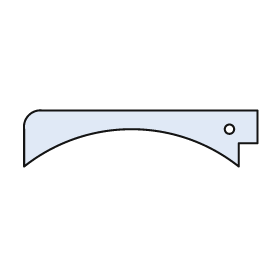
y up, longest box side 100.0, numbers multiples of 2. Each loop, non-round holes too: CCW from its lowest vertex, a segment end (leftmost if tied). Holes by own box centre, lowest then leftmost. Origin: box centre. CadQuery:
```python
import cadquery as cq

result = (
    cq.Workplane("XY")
    .moveTo(-50.0, -12.0)
    .threePointArc((-4.0, 4.0), (42.0, -12.0))
    .lineTo(42.0, -2.0)
    .lineTo(50.0, -2.0)
    .lineTo(50.0, 12.0)
    .lineTo(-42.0, 12.0)
    .threePointArc((-48.0, 10.0), (-50.0, 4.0))
    .close()
    .moveTo(38.0, 4.0)
    .circle(2.0)
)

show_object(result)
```